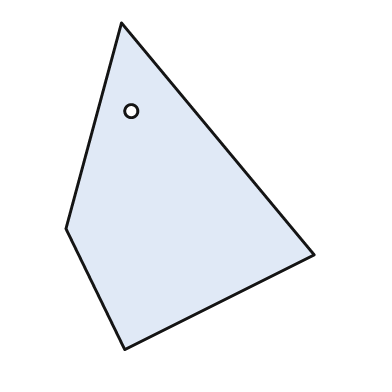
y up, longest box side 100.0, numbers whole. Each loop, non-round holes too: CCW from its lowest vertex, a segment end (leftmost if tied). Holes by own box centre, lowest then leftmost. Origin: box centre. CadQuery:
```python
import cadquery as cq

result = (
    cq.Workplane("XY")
    .moveTo(-20.0, -50.0)
    .lineTo(38.0, -21.0)
    .lineTo(-21.0, 50.0)
    .lineTo(-38.0, -13.0)
    .close()
    .moveTo(-18.0, 23.0)
    .circle(2.0)
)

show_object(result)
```